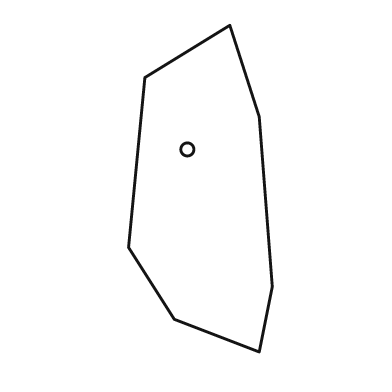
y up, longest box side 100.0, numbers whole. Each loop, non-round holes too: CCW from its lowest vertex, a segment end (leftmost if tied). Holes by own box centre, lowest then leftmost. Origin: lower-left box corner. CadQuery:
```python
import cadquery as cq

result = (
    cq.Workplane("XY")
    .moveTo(40.0, 0.0)
    .lineTo(44.0, 20.0)
    .lineTo(40.0, 72.0)
    .lineTo(31.0, 100.0)
    .lineTo(5.0, 84.0)
    .lineTo(0.0, 32.0)
    .lineTo(14.0, 10.0)
    .close()
    .moveTo(18.0, 62.0)
    .circle(2.0)
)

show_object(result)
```